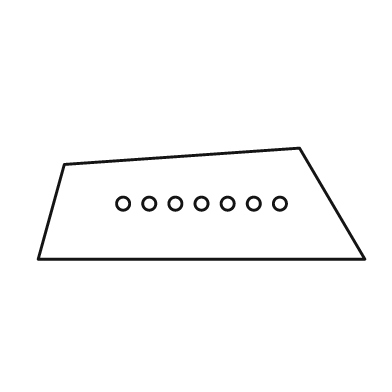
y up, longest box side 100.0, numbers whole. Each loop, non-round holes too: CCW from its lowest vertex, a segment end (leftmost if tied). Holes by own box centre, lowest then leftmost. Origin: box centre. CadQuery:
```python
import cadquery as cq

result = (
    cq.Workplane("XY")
    .moveTo(-50.0, -17.0)
    .lineTo(50.0, -17.0)
    .lineTo(30.0, 17.0)
    .lineTo(-42.0, 12.0)
    .close()
    .moveTo(-24.0, 0.0)
    .circle(2.0)
    .moveTo(-16.0, 0.0)
    .circle(2.0)
    .moveTo(-8.0, 0.0)
    .circle(2.0)
    .moveTo(0.0, 0.0)
    .circle(2.0)
    .moveTo(8.0, 0.0)
    .circle(2.0)
    .moveTo(16.0, 0.0)
    .circle(2.0)
    .moveTo(24.0, 0.0)
    .circle(2.0)
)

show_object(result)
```